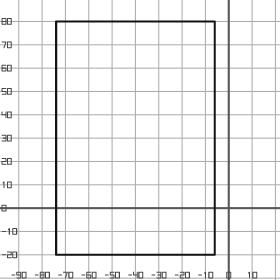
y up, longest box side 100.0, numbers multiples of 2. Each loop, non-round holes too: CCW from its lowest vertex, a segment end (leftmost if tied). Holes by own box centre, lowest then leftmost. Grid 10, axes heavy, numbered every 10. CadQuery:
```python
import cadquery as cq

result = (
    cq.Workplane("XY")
    .moveTo(-74.0, -20.0)
    .lineTo(-6.0, -20.0)
    .lineTo(-6.0, 80.0)
    .lineTo(-74.0, 80.0)
    .close()
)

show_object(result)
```